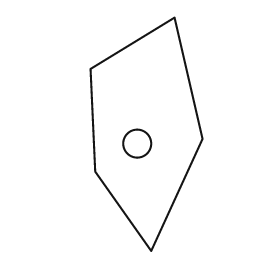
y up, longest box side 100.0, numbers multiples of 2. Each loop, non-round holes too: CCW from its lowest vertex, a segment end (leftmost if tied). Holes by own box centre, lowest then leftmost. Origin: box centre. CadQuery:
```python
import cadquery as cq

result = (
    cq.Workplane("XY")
    .moveTo(2.0, -50.0)
    .lineTo(24.0, -2.0)
    .lineTo(12.0, 50.0)
    .lineTo(-24.0, 28.0)
    .lineTo(-22.0, -16.0)
    .close()
    .moveTo(-4.0, -4.0)
    .circle(6.0)
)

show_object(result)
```